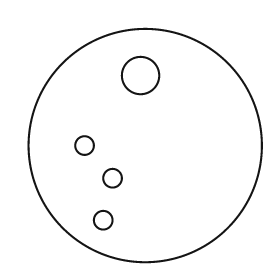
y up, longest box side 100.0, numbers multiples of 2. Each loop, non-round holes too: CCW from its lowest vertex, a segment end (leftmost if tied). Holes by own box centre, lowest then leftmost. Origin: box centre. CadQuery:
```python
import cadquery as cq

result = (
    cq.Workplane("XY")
    .moveTo(0.0, 0.0)
    .circle(50.0)
    .moveTo(-18.0, -32.0)
    .circle(4.0)
    .moveTo(-14.0, -14.0)
    .circle(4.0)
    .moveTo(-26.0, 0.0)
    .circle(4.0)
    .moveTo(-2.0, 30.0)
    .circle(8.0)
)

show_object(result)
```